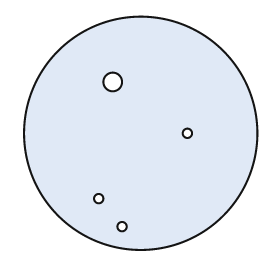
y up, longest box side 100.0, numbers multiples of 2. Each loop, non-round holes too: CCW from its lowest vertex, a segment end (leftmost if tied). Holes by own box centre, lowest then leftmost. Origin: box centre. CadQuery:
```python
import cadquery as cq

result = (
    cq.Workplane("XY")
    .moveTo(0.0, 0.0)
    .circle(50.0)
    .moveTo(-8.0, -40.0)
    .circle(2.0)
    .moveTo(-18.0, -28.0)
    .circle(2.0)
    .moveTo(20.0, 0.0)
    .circle(2.0)
    .moveTo(-12.0, 22.0)
    .circle(4.0)
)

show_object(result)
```